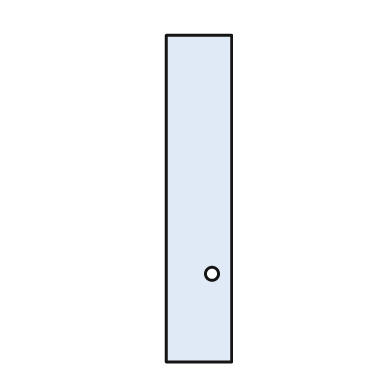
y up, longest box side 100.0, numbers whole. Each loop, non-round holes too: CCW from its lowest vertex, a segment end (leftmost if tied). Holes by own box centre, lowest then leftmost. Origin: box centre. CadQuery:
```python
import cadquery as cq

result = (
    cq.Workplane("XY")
    .moveTo(-10.0, -50.0)
    .lineTo(10.0, -50.0)
    .lineTo(10.0, 50.0)
    .lineTo(-10.0, 50.0)
    .close()
    .moveTo(4.0, -23.0)
    .circle(2.0)
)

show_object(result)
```